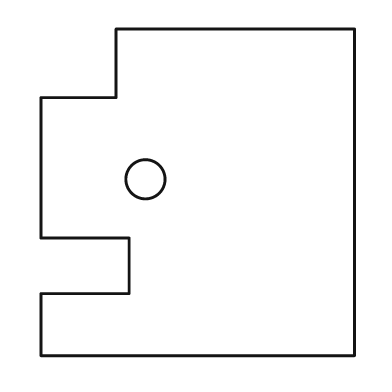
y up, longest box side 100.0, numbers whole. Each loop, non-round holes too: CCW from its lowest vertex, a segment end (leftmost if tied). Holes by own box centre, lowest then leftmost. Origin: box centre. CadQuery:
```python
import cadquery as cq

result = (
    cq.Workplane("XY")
    .moveTo(-48.0, -50.0)
    .lineTo(48.0, -50.0)
    .lineTo(48.0, 50.0)
    .lineTo(-25.0, 50.0)
    .lineTo(-25.0, 29.0)
    .lineTo(-48.0, 29.0)
    .lineTo(-48.0, -14.0)
    .lineTo(-21.0, -14.0)
    .lineTo(-21.0, -31.0)
    .lineTo(-48.0, -31.0)
    .close()
    .moveTo(-16.0, 4.0)
    .circle(6.0)
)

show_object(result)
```